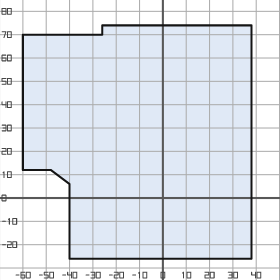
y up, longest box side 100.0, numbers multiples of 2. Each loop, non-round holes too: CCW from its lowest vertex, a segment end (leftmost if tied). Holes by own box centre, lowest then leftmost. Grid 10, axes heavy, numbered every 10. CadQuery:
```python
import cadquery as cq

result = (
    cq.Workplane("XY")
    .moveTo(-40.0, -26.0)
    .lineTo(38.0, -26.0)
    .lineTo(38.0, 74.0)
    .lineTo(-26.0, 74.0)
    .lineTo(-26.0, 70.0)
    .lineTo(-60.0, 70.0)
    .lineTo(-60.0, 12.0)
    .lineTo(-48.0, 12.0)
    .lineTo(-40.0, 6.0)
    .close()
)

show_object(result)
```